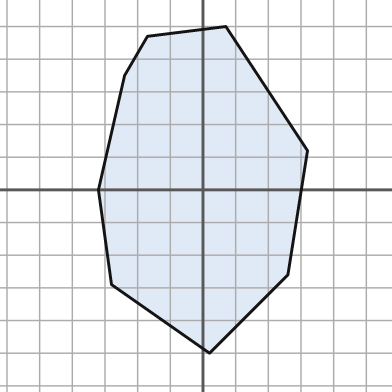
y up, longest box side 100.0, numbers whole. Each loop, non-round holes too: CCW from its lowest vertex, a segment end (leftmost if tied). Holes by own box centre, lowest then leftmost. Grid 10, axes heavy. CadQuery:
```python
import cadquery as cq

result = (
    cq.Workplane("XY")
    .moveTo(2.0, -50.0)
    .lineTo(26.0, -26.0)
    .lineTo(32.0, 12.0)
    .lineTo(7.0, 50.0)
    .lineTo(-17.0, 47.0)
    .lineTo(-24.0, 35.0)
    .lineTo(-32.0, 0.0)
    .lineTo(-28.0, -29.0)
    .close()
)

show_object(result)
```